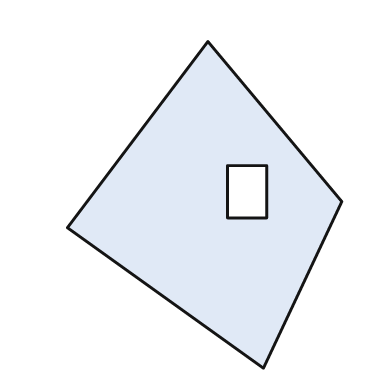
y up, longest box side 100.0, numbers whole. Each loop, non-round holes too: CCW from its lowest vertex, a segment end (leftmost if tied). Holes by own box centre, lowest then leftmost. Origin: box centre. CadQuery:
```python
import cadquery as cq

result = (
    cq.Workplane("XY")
    .moveTo(18.0, -50.0)
    .lineTo(42.0, 1.0)
    .lineTo(1.0, 50.0)
    .lineTo(-42.0, -7.0)
    .close()
    .moveTo(7.0, -4.0)
    .lineTo(19.0, -4.0)
    .lineTo(19.0, 12.0)
    .lineTo(7.0, 12.0)
    .close()
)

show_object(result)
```